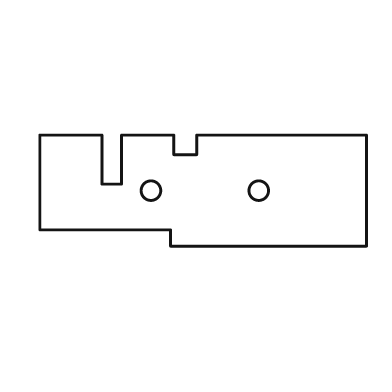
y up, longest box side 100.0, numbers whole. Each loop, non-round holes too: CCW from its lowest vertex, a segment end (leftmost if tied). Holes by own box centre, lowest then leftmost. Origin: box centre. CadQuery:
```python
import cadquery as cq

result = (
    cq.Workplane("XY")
    .moveTo(-10.0, -17.0)
    .lineTo(50.0, -17.0)
    .lineTo(50.0, 17.0)
    .lineTo(-2.0, 17.0)
    .lineTo(-2.0, 11.0)
    .lineTo(-9.0, 11.0)
    .lineTo(-9.0, 17.0)
    .lineTo(-25.0, 17.0)
    .lineTo(-25.0, 2.0)
    .lineTo(-31.0, 2.0)
    .lineTo(-31.0, 17.0)
    .lineTo(-50.0, 17.0)
    .lineTo(-50.0, -12.0)
    .lineTo(-10.0, -12.0)
    .close()
    .moveTo(-16.0, 0.0)
    .circle(3.0)
    .moveTo(17.0, 0.0)
    .circle(3.0)
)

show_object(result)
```